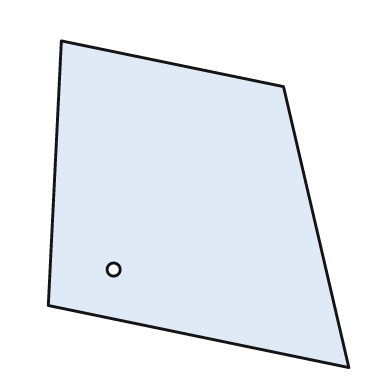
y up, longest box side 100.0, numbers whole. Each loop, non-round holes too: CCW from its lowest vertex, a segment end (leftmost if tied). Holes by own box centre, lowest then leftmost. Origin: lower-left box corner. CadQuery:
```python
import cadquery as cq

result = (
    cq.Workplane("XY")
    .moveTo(92.0, 0.0)
    .lineTo(72.0, 86.0)
    .lineTo(4.0, 100.0)
    .lineTo(0.0, 19.0)
    .close()
    .moveTo(20.0, 30.0)
    .circle(2.0)
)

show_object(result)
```